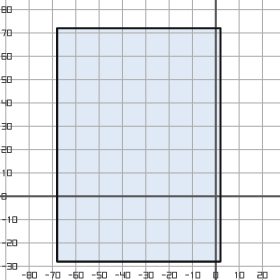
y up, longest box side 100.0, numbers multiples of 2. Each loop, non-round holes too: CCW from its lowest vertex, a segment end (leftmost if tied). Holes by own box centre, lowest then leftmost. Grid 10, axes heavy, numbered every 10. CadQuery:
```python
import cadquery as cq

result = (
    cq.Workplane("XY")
    .moveTo(-68.0, -28.0)
    .lineTo(2.0, -28.0)
    .lineTo(2.0, 72.0)
    .lineTo(-68.0, 72.0)
    .close()
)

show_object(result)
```